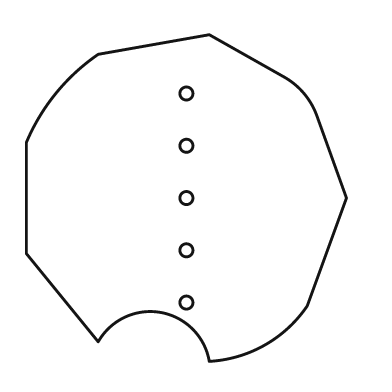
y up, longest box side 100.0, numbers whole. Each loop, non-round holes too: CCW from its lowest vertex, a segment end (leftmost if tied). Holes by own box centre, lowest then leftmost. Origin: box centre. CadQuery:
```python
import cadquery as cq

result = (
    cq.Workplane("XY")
    .moveTo(7.0, -50.0)
    .threePointArc((24.0, -45.0), (37.0, -33.0))
    .lineTo(49.0, 0.0)
    .lineTo(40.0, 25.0)
    .threePointArc((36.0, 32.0), (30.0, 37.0))
    .lineTo(7.0, 50.0)
    .lineTo(-27.0, 44.0)
    .threePointArc((-40.0, 32.0), (-49.0, 17.0))
    .lineTo(-49.0, -17.0)
    .lineTo(-27.0, -44.0)
    .threePointArc((-8.0, -35.0), (7.0, -50.0))
    .close()
    .moveTo(0.0, -32.0)
    .circle(2.0)
    .moveTo(0.0, -16.0)
    .circle(2.0)
    .moveTo(0.0, 0.0)
    .circle(2.0)
    .moveTo(0.0, 16.0)
    .circle(2.0)
    .moveTo(0.0, 32.0)
    .circle(2.0)
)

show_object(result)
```